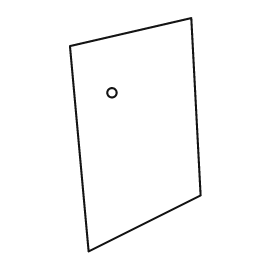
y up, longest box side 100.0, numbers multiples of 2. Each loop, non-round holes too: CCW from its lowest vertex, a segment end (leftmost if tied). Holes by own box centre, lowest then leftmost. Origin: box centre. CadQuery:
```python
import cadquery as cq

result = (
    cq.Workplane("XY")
    .moveTo(-20.0, -50.0)
    .lineTo(28.0, -26.0)
    .lineTo(24.0, 50.0)
    .lineTo(-28.0, 38.0)
    .close()
    .moveTo(-10.0, 18.0)
    .circle(2.0)
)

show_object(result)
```